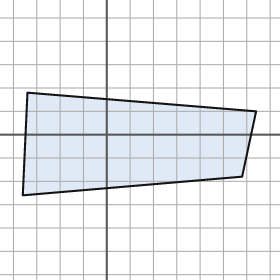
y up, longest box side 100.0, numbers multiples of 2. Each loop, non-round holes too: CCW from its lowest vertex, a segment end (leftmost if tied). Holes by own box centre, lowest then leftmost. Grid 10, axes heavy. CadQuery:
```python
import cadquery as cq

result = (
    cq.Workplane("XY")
    .moveTo(-36.0, -26.0)
    .lineTo(58.0, -18.0)
    .lineTo(64.0, 10.0)
    .lineTo(-34.0, 18.0)
    .close()
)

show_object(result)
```